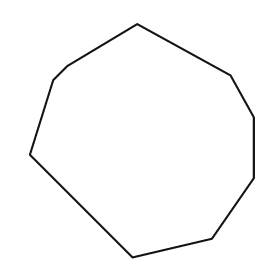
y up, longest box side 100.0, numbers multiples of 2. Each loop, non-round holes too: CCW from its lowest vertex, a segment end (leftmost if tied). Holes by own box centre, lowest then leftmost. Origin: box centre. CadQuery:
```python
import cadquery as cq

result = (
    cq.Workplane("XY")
    .moveTo(-4.0, -50.0)
    .lineTo(30.0, -42.0)
    .lineTo(48.0, -16.0)
    .lineTo(48.0, 10.0)
    .lineTo(38.0, 28.0)
    .lineTo(-2.0, 50.0)
    .lineTo(-32.0, 32.0)
    .lineTo(-38.0, 26.0)
    .lineTo(-48.0, -6.0)
    .close()
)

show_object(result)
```